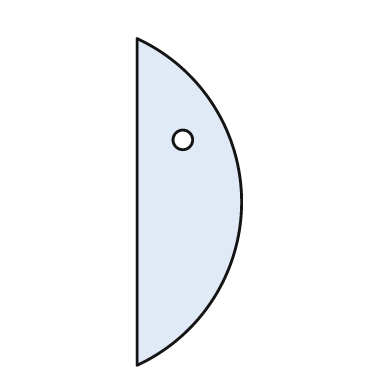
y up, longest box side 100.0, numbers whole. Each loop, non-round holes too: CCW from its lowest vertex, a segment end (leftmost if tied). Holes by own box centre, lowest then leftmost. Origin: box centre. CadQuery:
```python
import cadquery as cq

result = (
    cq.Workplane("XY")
    .moveTo(-16.0, -50.0)
    .threePointArc((16.0, 0.0), (-16.0, 50.0))
    .close()
    .moveTo(-2.0, 19.0)
    .circle(3.0)
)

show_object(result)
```